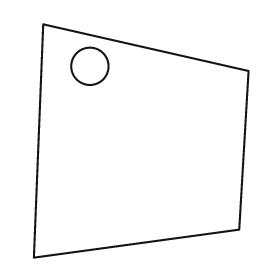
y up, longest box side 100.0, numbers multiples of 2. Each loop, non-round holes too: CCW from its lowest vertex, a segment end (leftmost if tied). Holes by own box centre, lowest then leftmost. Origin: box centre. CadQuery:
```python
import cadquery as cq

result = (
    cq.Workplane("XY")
    .moveTo(-46.0, -50.0)
    .lineTo(42.0, -38.0)
    .lineTo(46.0, 30.0)
    .lineTo(-42.0, 50.0)
    .close()
    .moveTo(-22.0, 32.0)
    .circle(8.0)
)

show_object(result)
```